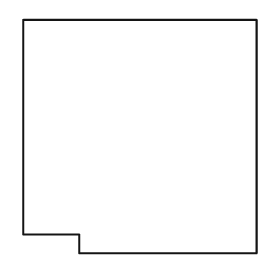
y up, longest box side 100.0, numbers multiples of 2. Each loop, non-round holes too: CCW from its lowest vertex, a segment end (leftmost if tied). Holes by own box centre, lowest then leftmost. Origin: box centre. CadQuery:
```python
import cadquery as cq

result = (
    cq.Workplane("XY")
    .moveTo(-26.0, -50.0)
    .lineTo(50.0, -50.0)
    .lineTo(50.0, 50.0)
    .lineTo(-50.0, 50.0)
    .lineTo(-50.0, -42.0)
    .lineTo(-26.0, -42.0)
    .close()
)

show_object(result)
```